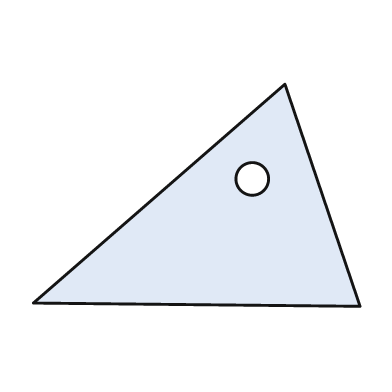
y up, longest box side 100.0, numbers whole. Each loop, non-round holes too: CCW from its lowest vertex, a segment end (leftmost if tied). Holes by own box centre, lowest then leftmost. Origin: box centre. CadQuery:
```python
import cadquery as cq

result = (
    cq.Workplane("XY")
    .moveTo(50.0, -34.0)
    .lineTo(27.0, 34.0)
    .lineTo(-50.0, -33.0)
    .close()
    .moveTo(17.0, 5.0)
    .circle(5.0)
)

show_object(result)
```